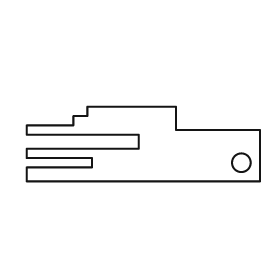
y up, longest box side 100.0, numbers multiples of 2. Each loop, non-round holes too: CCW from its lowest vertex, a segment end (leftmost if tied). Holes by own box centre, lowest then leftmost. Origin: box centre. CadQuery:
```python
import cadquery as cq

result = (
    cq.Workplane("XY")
    .moveTo(-50.0, -16.0)
    .lineTo(50.0, -16.0)
    .lineTo(50.0, 6.0)
    .lineTo(14.0, 6.0)
    .lineTo(14.0, 16.0)
    .lineTo(-24.0, 16.0)
    .lineTo(-24.0, 12.0)
    .lineTo(-30.0, 12.0)
    .lineTo(-30.0, 8.0)
    .lineTo(-50.0, 8.0)
    .lineTo(-50.0, 4.0)
    .lineTo(-2.0, 4.0)
    .lineTo(-2.0, -2.0)
    .lineTo(-50.0, -2.0)
    .lineTo(-50.0, -6.0)
    .lineTo(-22.0, -6.0)
    .lineTo(-22.0, -10.0)
    .lineTo(-50.0, -10.0)
    .close()
    .moveTo(42.0, -8.0)
    .circle(4.0)
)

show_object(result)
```